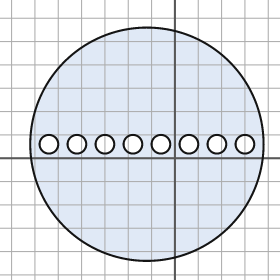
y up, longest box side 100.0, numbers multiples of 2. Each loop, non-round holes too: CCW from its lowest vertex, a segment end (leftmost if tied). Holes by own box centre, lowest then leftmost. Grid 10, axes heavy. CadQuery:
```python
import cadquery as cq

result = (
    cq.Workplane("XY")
    .moveTo(-12.0, 6.0)
    .circle(50.0)
    .moveTo(-54.0, 6.0)
    .circle(4.0)
    .moveTo(-42.0, 6.0)
    .circle(4.0)
    .moveTo(-30.0, 6.0)
    .circle(4.0)
    .moveTo(-18.0, 6.0)
    .circle(4.0)
    .moveTo(-6.0, 6.0)
    .circle(4.0)
    .moveTo(6.0, 6.0)
    .circle(4.0)
    .moveTo(18.0, 6.0)
    .circle(4.0)
    .moveTo(30.0, 6.0)
    .circle(4.0)
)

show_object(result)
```